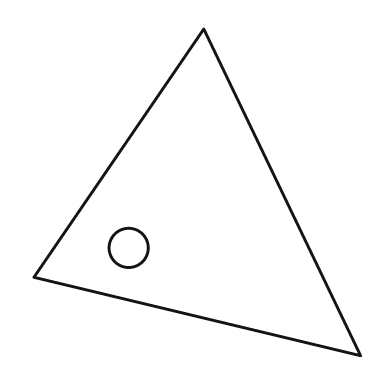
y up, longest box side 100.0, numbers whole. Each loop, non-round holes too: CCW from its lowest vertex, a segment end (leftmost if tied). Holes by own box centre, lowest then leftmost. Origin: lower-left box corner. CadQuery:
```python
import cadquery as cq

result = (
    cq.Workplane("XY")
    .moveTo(100.0, 0.0)
    .lineTo(52.0, 100.0)
    .lineTo(0.0, 24.0)
    .close()
    .moveTo(29.0, 33.0)
    .circle(6.0)
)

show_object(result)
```